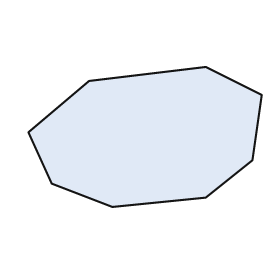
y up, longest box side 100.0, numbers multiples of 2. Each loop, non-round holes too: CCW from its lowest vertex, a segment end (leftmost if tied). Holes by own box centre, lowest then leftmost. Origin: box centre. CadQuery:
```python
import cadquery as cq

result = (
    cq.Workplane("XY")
    .moveTo(-14.0, -30.0)
    .lineTo(26.0, -26.0)
    .lineTo(46.0, -10.0)
    .lineTo(50.0, 18.0)
    .lineTo(26.0, 30.0)
    .lineTo(-24.0, 24.0)
    .lineTo(-50.0, 2.0)
    .lineTo(-40.0, -20.0)
    .close()
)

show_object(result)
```